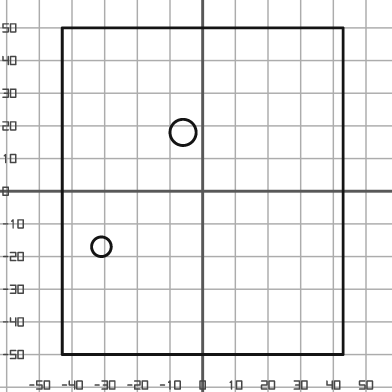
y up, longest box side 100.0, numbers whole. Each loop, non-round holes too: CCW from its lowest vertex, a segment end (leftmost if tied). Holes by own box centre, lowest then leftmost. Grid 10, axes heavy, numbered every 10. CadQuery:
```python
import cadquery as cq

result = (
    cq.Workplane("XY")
    .moveTo(-43.0, -50.0)
    .lineTo(43.0, -50.0)
    .lineTo(43.0, 50.0)
    .lineTo(-43.0, 50.0)
    .close()
    .moveTo(-31.0, -17.0)
    .circle(3.0)
    .moveTo(-6.0, 18.0)
    .circle(4.0)
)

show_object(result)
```